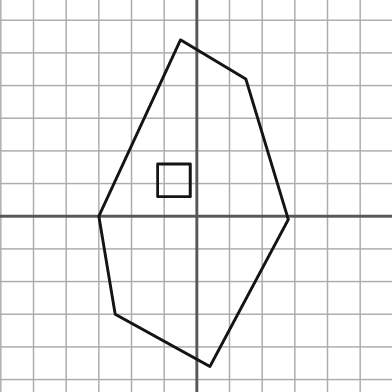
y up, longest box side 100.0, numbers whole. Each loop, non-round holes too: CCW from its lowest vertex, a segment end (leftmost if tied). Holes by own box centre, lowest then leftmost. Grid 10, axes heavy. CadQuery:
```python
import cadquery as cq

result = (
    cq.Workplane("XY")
    .moveTo(4.0, -46.0)
    .lineTo(28.0, -1.0)
    .lineTo(15.0, 42.0)
    .lineTo(-5.0, 54.0)
    .lineTo(-30.0, 0.0)
    .lineTo(-25.0, -30.0)
    .close()
    .moveTo(-12.0, 6.0)
    .lineTo(-2.0, 6.0)
    .lineTo(-2.0, 16.0)
    .lineTo(-12.0, 16.0)
    .close()
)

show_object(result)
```